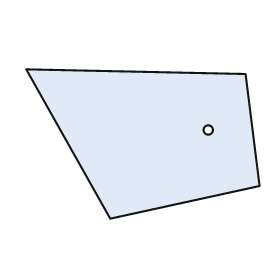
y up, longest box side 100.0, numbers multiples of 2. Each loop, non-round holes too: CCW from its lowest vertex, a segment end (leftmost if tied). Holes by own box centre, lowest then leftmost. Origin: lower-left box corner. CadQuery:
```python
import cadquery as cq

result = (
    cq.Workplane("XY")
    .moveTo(36.0, 0.0)
    .lineTo(100.0, 14.0)
    .lineTo(94.0, 62.0)
    .lineTo(0.0, 64.0)
    .close()
    .moveTo(78.0, 38.0)
    .circle(2.0)
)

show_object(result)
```